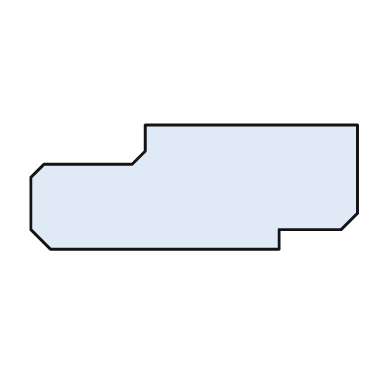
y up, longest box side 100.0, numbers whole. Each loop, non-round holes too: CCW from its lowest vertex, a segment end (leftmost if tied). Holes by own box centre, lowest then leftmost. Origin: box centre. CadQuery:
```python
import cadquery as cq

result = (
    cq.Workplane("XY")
    .moveTo(-44.0, -19.0)
    .lineTo(26.0, -19.0)
    .lineTo(26.0, -13.0)
    .lineTo(45.0, -13.0)
    .lineTo(50.0, -8.0)
    .lineTo(50.0, 19.0)
    .lineTo(-15.0, 19.0)
    .lineTo(-15.0, 11.0)
    .lineTo(-19.0, 7.0)
    .lineTo(-46.0, 7.0)
    .lineTo(-50.0, 3.0)
    .lineTo(-50.0, -13.0)
    .close()
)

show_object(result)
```